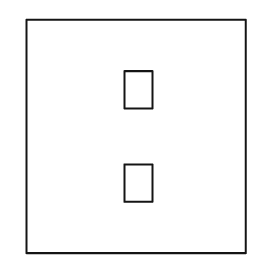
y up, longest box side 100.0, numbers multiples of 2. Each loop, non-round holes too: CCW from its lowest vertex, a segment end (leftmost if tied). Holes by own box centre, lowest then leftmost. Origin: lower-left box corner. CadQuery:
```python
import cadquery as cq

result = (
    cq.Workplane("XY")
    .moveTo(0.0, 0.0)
    .lineTo(94.0, 0.0)
    .lineTo(94.0, 100.0)
    .lineTo(0.0, 100.0)
    .close()
    .moveTo(42.0, 22.0)
    .lineTo(54.0, 22.0)
    .lineTo(54.0, 38.0)
    .lineTo(42.0, 38.0)
    .close()
    .moveTo(42.0, 62.0)
    .lineTo(54.0, 62.0)
    .lineTo(54.0, 78.0)
    .lineTo(42.0, 78.0)
    .close()
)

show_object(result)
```